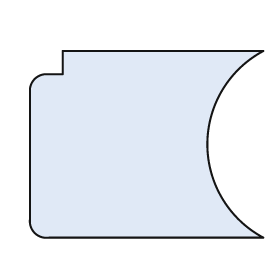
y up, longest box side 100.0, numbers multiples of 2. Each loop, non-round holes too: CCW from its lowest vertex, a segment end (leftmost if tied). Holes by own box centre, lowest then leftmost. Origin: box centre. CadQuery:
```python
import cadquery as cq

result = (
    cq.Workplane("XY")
    .moveTo(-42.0, -40.0)
    .lineTo(50.0, -40.0)
    .threePointArc((26.0, 0.0), (50.0, 40.0))
    .lineTo(-36.0, 40.0)
    .lineTo(-36.0, 30.0)
    .lineTo(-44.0, 30.0)
    .threePointArc((-48.0, 28.0), (-50.0, 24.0))
    .lineTo(-50.0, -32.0)
    .threePointArc((-48.0, -38.0), (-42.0, -40.0))
    .close()
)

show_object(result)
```